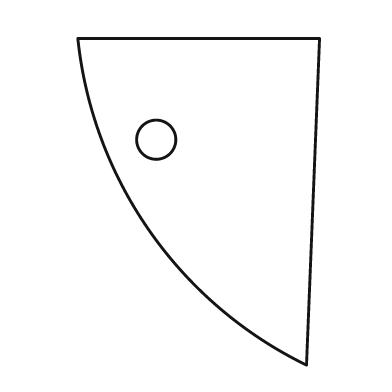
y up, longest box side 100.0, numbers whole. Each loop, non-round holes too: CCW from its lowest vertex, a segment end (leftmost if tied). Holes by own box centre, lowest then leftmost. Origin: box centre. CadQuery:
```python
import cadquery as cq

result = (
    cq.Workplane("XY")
    .moveTo(33.0, -50.0)
    .lineTo(37.0, 50.0)
    .lineTo(-37.0, 50.0)
    .threePointArc((-15.0, -9.0), (33.0, -50.0))
    .close()
    .moveTo(-13.0, 19.0)
    .circle(6.0)
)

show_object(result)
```